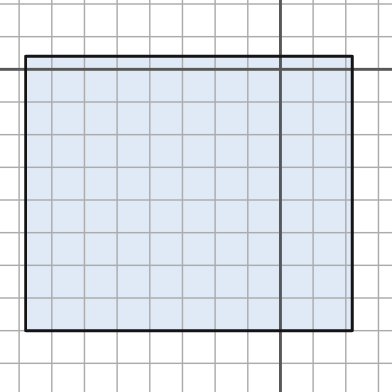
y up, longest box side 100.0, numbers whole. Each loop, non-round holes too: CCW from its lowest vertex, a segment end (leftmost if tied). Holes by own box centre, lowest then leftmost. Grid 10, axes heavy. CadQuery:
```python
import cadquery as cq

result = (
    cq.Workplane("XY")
    .moveTo(-78.0, -80.0)
    .lineTo(22.0, -80.0)
    .lineTo(22.0, 4.0)
    .lineTo(-78.0, 4.0)
    .close()
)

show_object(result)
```